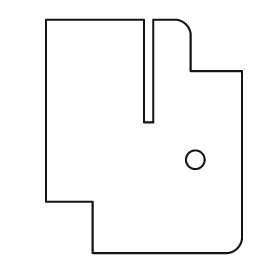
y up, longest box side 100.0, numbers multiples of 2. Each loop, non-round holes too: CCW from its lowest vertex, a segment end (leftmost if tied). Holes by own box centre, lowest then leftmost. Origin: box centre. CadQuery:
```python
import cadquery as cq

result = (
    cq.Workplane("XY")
    .moveTo(-22.0, -50.0)
    .lineTo(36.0, -50.0)
    .threePointArc((40.0, -48.0), (42.0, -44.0))
    .lineTo(42.0, 28.0)
    .lineTo(20.0, 28.0)
    .lineTo(20.0, 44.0)
    .threePointArc((18.0, 48.0), (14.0, 50.0))
    .lineTo(4.0, 50.0)
    .lineTo(4.0, 6.0)
    .lineTo(0.0, 6.0)
    .lineTo(0.0, 50.0)
    .lineTo(-42.0, 50.0)
    .lineTo(-42.0, -28.0)
    .lineTo(-22.0, -28.0)
    .close()
    .moveTo(22.0, -10.0)
    .circle(4.0)
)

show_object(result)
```